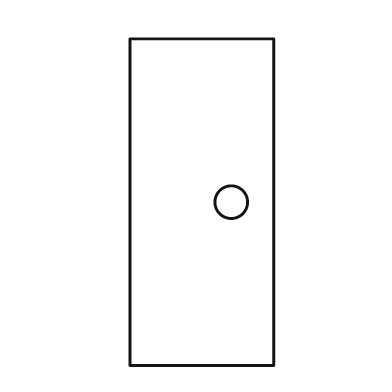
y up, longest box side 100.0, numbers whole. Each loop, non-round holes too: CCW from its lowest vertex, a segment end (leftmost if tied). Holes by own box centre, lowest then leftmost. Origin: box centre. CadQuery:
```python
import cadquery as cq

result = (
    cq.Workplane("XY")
    .moveTo(-22.0, -50.0)
    .lineTo(22.0, -50.0)
    .lineTo(22.0, 50.0)
    .lineTo(-22.0, 50.0)
    .close()
    .moveTo(9.0, 0.0)
    .circle(5.0)
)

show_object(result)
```